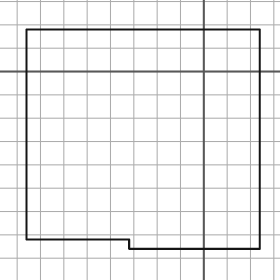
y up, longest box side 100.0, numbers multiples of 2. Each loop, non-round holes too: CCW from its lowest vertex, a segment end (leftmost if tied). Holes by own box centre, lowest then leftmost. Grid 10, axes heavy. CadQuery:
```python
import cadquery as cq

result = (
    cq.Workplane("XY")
    .moveTo(-32.0, -76.0)
    .lineTo(24.0, -76.0)
    .lineTo(24.0, 18.0)
    .lineTo(-76.0, 18.0)
    .lineTo(-76.0, -72.0)
    .lineTo(-32.0, -72.0)
    .close()
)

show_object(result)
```